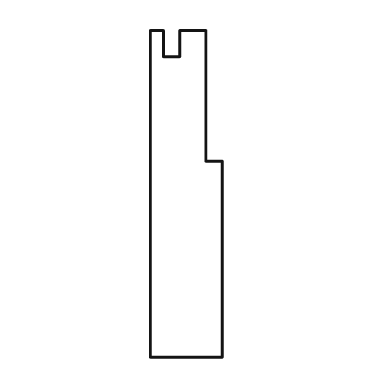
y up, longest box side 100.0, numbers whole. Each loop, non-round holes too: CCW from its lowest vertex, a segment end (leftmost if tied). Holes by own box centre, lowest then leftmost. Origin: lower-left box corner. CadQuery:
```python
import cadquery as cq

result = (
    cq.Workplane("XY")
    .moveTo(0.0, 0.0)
    .lineTo(22.0, 0.0)
    .lineTo(22.0, 60.0)
    .lineTo(17.0, 60.0)
    .lineTo(17.0, 100.0)
    .lineTo(9.0, 100.0)
    .lineTo(9.0, 92.0)
    .lineTo(4.0, 92.0)
    .lineTo(4.0, 100.0)
    .lineTo(0.0, 100.0)
    .close()
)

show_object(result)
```